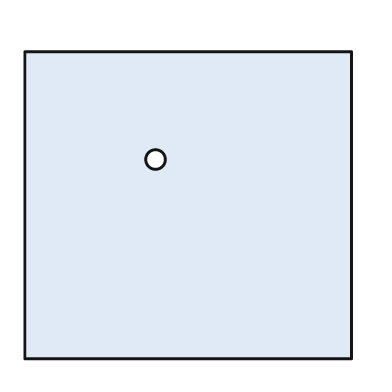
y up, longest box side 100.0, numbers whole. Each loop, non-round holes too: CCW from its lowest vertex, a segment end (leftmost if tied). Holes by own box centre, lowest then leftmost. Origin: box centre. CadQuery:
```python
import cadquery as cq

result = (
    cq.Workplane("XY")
    .moveTo(-50.0, -47.0)
    .lineTo(50.0, -47.0)
    .lineTo(50.0, 47.0)
    .lineTo(-50.0, 47.0)
    .close()
    .moveTo(-10.0, 14.0)
    .circle(3.0)
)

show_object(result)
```